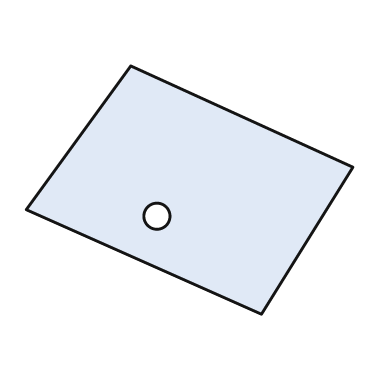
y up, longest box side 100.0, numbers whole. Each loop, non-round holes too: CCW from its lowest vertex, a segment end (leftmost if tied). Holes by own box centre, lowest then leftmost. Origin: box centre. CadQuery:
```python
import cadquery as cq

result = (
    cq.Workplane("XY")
    .moveTo(22.0, -38.0)
    .lineTo(50.0, 7.0)
    .lineTo(-18.0, 38.0)
    .lineTo(-50.0, -6.0)
    .close()
    .moveTo(-10.0, -8.0)
    .circle(4.0)
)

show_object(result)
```